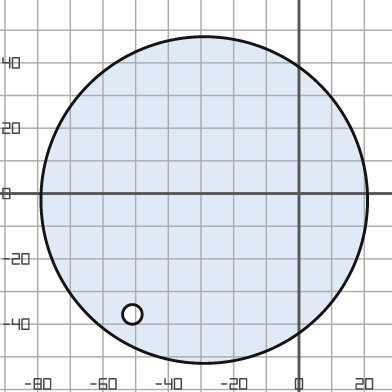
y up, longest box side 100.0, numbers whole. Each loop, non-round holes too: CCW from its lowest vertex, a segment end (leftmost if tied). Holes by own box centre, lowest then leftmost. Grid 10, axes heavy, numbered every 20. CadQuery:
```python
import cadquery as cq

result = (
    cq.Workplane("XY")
    .moveTo(-29.0, -2.0)
    .circle(50.0)
    .moveTo(-51.0, -37.0)
    .circle(3.0)
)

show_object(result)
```